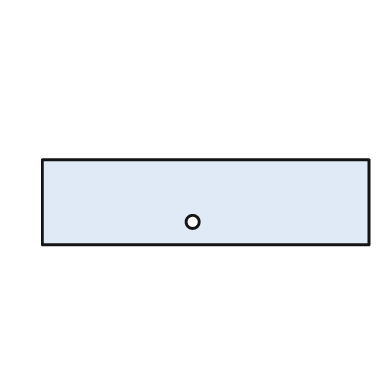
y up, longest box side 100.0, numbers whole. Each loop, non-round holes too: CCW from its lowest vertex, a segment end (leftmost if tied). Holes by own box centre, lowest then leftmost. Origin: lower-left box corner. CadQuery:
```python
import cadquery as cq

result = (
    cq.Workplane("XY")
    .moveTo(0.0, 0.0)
    .lineTo(100.0, 0.0)
    .lineTo(100.0, 26.0)
    .lineTo(0.0, 26.0)
    .close()
    .moveTo(46.0, 7.0)
    .circle(2.0)
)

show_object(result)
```